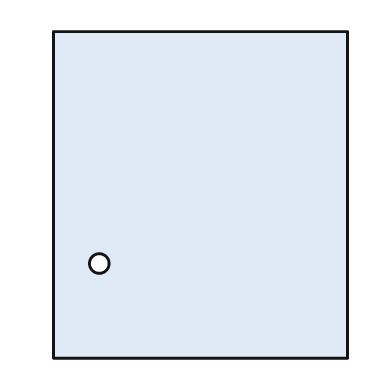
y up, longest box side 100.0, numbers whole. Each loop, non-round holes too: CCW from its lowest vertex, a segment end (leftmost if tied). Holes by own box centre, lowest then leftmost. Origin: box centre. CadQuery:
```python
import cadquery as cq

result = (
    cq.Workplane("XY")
    .moveTo(-45.0, -50.0)
    .lineTo(45.0, -50.0)
    .lineTo(45.0, 50.0)
    .lineTo(-45.0, 50.0)
    .close()
    .moveTo(-31.0, -21.0)
    .circle(3.0)
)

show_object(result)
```